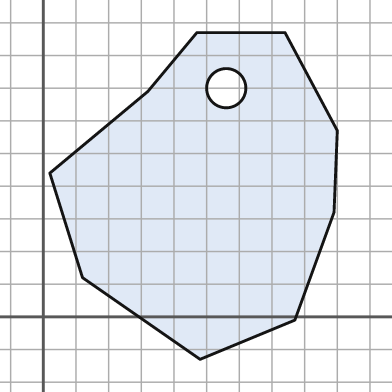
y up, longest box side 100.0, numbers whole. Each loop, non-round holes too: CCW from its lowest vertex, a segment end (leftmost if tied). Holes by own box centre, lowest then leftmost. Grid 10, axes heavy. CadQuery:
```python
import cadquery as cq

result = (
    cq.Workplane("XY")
    .moveTo(48.0, -13.0)
    .lineTo(77.0, -1.0)
    .lineTo(89.0, 32.0)
    .lineTo(90.0, 57.0)
    .lineTo(74.0, 87.0)
    .lineTo(47.0, 87.0)
    .lineTo(32.0, 69.0)
    .lineTo(2.0, 44.0)
    .lineTo(12.0, 12.0)
    .close()
    .moveTo(56.0, 70.0)
    .circle(6.0)
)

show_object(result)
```